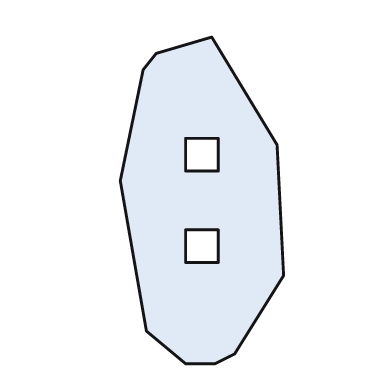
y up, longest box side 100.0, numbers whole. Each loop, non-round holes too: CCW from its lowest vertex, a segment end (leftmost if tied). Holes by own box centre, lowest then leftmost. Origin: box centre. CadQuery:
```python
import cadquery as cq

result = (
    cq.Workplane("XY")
    .moveTo(-5.0, -50.0)
    .lineTo(4.0, -50.0)
    .lineTo(10.0, -47.0)
    .lineTo(25.0, -23.0)
    .lineTo(23.0, 17.0)
    .lineTo(3.0, 50.0)
    .lineTo(-14.0, 45.0)
    .lineTo(-18.0, 40.0)
    .lineTo(-25.0, 6.0)
    .lineTo(-17.0, -40.0)
    .close()
    .moveTo(-5.0, -19.0)
    .lineTo(5.0, -19.0)
    .lineTo(5.0, -9.0)
    .lineTo(-5.0, -9.0)
    .close()
    .moveTo(-5.0, 9.0)
    .lineTo(5.0, 9.0)
    .lineTo(5.0, 19.0)
    .lineTo(-5.0, 19.0)
    .close()
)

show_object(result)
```